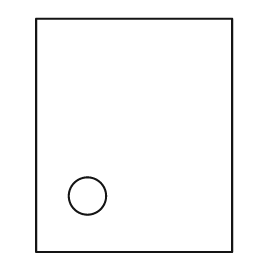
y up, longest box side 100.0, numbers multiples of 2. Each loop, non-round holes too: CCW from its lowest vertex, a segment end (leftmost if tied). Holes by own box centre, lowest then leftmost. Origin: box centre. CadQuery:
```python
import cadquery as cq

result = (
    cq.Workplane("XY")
    .moveTo(-42.0, -50.0)
    .lineTo(42.0, -50.0)
    .lineTo(42.0, 50.0)
    .lineTo(-42.0, 50.0)
    .close()
    .moveTo(-20.0, -26.0)
    .circle(8.0)
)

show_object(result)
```